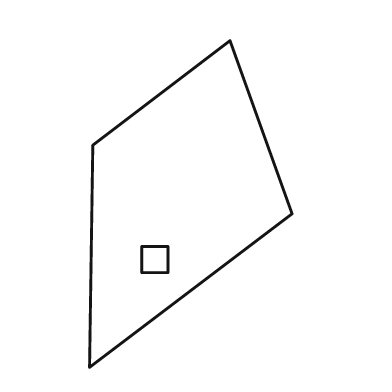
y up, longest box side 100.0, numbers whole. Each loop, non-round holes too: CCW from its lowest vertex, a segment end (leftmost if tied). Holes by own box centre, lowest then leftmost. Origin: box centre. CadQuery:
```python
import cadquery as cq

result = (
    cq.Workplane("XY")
    .moveTo(-31.0, -50.0)
    .lineTo(31.0, -3.0)
    .lineTo(12.0, 50.0)
    .lineTo(-30.0, 18.0)
    .close()
    .moveTo(-15.0, -21.0)
    .lineTo(-7.0, -21.0)
    .lineTo(-7.0, -13.0)
    .lineTo(-15.0, -13.0)
    .close()
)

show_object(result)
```